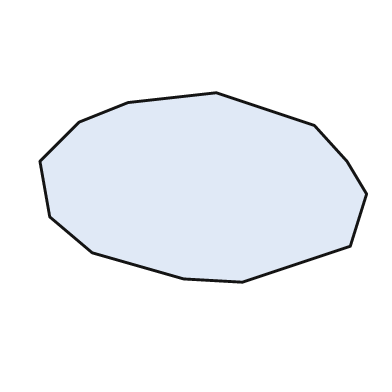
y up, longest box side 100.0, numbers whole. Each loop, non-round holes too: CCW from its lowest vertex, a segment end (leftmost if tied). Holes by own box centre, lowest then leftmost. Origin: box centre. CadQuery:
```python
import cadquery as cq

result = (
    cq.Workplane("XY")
    .moveTo(12.0, -29.0)
    .lineTo(45.0, -18.0)
    .lineTo(50.0, -2.0)
    .lineTo(44.0, 8.0)
    .lineTo(34.0, 19.0)
    .lineTo(4.0, 29.0)
    .lineTo(-23.0, 26.0)
    .lineTo(-38.0, 20.0)
    .lineTo(-50.0, 8.0)
    .lineTo(-47.0, -9.0)
    .lineTo(-34.0, -20.0)
    .lineTo(-6.0, -28.0)
    .close()
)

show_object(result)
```